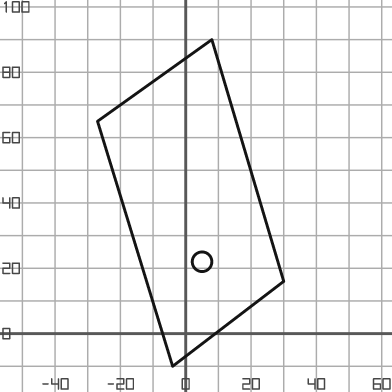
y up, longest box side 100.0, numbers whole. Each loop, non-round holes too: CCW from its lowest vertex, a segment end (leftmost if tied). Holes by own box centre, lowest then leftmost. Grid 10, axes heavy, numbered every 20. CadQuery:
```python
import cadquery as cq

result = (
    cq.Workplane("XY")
    .moveTo(-4.0, -10.0)
    .lineTo(30.0, 16.0)
    .lineTo(8.0, 90.0)
    .lineTo(-27.0, 65.0)
    .close()
    .moveTo(5.0, 22.0)
    .circle(3.0)
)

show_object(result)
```